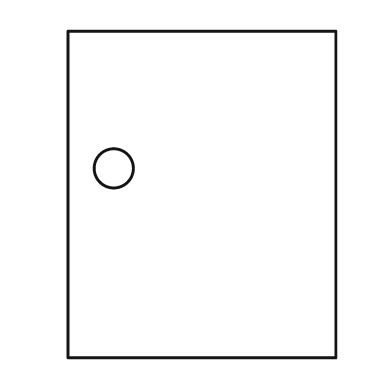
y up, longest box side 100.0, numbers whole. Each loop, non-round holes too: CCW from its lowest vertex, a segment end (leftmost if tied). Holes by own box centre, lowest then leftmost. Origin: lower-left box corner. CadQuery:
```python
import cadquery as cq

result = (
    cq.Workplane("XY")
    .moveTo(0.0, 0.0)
    .lineTo(82.0, 0.0)
    .lineTo(82.0, 100.0)
    .lineTo(0.0, 100.0)
    .close()
    .moveTo(14.0, 58.0)
    .circle(6.0)
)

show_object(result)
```